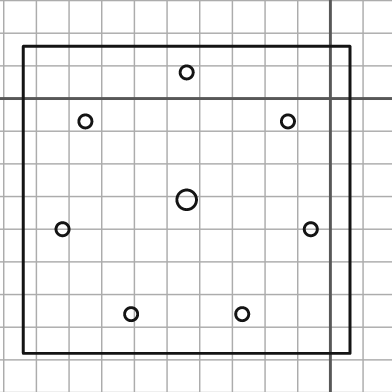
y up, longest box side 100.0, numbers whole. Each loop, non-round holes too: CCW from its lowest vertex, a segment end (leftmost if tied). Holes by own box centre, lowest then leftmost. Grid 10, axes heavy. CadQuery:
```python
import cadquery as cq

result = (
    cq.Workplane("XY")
    .moveTo(-94.0, -78.0)
    .lineTo(6.0, -78.0)
    .lineTo(6.0, 16.0)
    .lineTo(-94.0, 16.0)
    .close()
    .moveTo(-61.0, -66.0)
    .circle(2.0)
    .moveTo(-27.0, -66.0)
    .circle(2.0)
    .moveTo(-82.0, -40.0)
    .circle(2.0)
    .moveTo(-6.0, -40.0)
    .circle(2.0)
    .moveTo(-44.0, -31.0)
    .circle(3.0)
    .moveTo(-75.0, -7.0)
    .circle(2.0)
    .moveTo(-13.0, -7.0)
    .circle(2.0)
    .moveTo(-44.0, 8.0)
    .circle(2.0)
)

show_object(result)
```